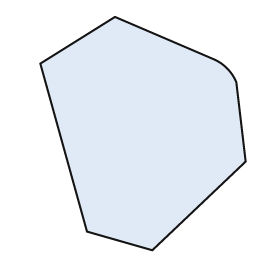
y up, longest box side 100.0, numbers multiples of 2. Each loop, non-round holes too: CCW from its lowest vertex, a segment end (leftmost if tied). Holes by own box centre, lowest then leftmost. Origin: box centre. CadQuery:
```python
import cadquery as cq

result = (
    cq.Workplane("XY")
    .moveTo(4.0, -50.0)
    .lineTo(44.0, -12.0)
    .lineTo(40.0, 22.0)
    .threePointArc((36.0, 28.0), (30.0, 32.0))
    .lineTo(-12.0, 50.0)
    .lineTo(-44.0, 30.0)
    .lineTo(-24.0, -42.0)
    .close()
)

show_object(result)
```